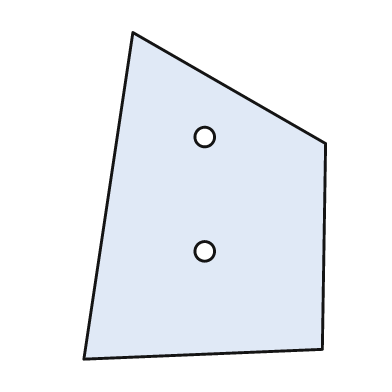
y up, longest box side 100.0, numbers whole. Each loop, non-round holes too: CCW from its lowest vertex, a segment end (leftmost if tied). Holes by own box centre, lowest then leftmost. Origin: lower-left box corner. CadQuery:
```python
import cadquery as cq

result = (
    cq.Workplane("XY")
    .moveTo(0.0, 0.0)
    .lineTo(73.0, 3.0)
    .lineTo(74.0, 66.0)
    .lineTo(15.0, 100.0)
    .close()
    .moveTo(37.0, 33.0)
    .circle(3.0)
    .moveTo(37.0, 68.0)
    .circle(3.0)
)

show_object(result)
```